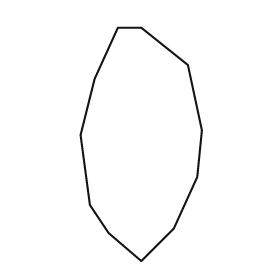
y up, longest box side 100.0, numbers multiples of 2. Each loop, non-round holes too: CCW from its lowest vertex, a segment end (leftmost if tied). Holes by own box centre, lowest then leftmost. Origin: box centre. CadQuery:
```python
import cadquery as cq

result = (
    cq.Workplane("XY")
    .moveTo(0.0, -50.0)
    .lineTo(14.0, -36.0)
    .lineTo(24.0, -14.0)
    .lineTo(26.0, 6.0)
    .lineTo(20.0, 34.0)
    .lineTo(0.0, 50.0)
    .lineTo(-10.0, 50.0)
    .lineTo(-20.0, 28.0)
    .lineTo(-26.0, 4.0)
    .lineTo(-22.0, -26.0)
    .lineTo(-14.0, -38.0)
    .close()
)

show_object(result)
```